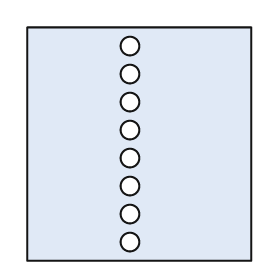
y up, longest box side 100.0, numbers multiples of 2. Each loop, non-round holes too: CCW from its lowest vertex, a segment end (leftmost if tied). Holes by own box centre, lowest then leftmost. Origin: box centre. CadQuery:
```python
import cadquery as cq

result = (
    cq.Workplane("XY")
    .moveTo(-48.0, -50.0)
    .lineTo(48.0, -50.0)
    .lineTo(48.0, 50.0)
    .lineTo(-48.0, 50.0)
    .close()
    .moveTo(-4.0, -42.0)
    .circle(4.0)
    .moveTo(-4.0, -30.0)
    .circle(4.0)
    .moveTo(-4.0, -18.0)
    .circle(4.0)
    .moveTo(-4.0, -6.0)
    .circle(4.0)
    .moveTo(-4.0, 6.0)
    .circle(4.0)
    .moveTo(-4.0, 18.0)
    .circle(4.0)
    .moveTo(-4.0, 30.0)
    .circle(4.0)
    .moveTo(-4.0, 42.0)
    .circle(4.0)
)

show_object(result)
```